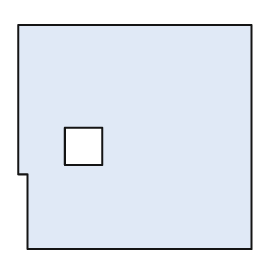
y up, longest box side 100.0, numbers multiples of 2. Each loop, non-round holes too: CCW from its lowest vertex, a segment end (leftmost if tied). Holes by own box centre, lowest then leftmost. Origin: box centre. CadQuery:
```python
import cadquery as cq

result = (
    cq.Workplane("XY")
    .moveTo(-46.0, -48.0)
    .lineTo(50.0, -48.0)
    .lineTo(50.0, 48.0)
    .lineTo(-50.0, 48.0)
    .lineTo(-50.0, -16.0)
    .lineTo(-46.0, -16.0)
    .close()
    .moveTo(-30.0, -12.0)
    .lineTo(-14.0, -12.0)
    .lineTo(-14.0, 4.0)
    .lineTo(-30.0, 4.0)
    .close()
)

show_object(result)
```